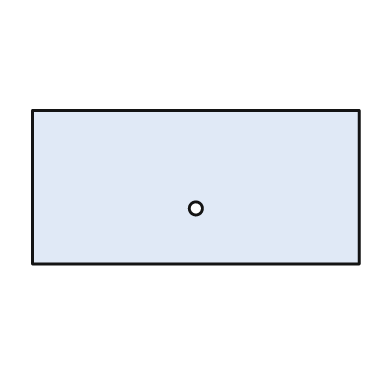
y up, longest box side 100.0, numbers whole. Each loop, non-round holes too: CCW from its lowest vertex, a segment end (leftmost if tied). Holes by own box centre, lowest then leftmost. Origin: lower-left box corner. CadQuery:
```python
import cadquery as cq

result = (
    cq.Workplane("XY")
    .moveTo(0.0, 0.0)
    .lineTo(100.0, 0.0)
    .lineTo(100.0, 47.0)
    .lineTo(0.0, 47.0)
    .close()
    .moveTo(50.0, 17.0)
    .circle(2.0)
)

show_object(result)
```